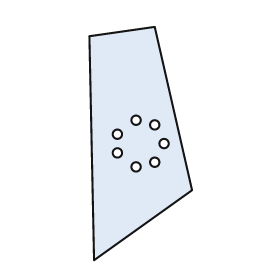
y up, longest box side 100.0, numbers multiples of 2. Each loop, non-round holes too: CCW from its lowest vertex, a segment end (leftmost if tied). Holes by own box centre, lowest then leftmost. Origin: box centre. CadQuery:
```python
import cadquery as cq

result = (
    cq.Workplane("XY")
    .moveTo(-20.0, -50.0)
    .lineTo(22.0, -20.0)
    .lineTo(6.0, 50.0)
    .lineTo(-22.0, 46.0)
    .close()
    .moveTo(-2.0, -10.0)
    .circle(2.0)
    .moveTo(6.0, -8.0)
    .circle(2.0)
    .moveTo(-10.0, -4.0)
    .circle(2.0)
    .moveTo(10.0, 0.0)
    .circle(2.0)
    .moveTo(-10.0, 4.0)
    .circle(2.0)
    .moveTo(6.0, 8.0)
    .circle(2.0)
    .moveTo(-2.0, 10.0)
    .circle(2.0)
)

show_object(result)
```